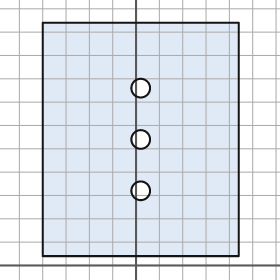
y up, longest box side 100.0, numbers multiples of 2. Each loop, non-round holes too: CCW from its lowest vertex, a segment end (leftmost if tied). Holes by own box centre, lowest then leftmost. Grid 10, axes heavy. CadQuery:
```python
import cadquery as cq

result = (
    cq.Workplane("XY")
    .moveTo(-40.0, 4.0)
    .lineTo(44.0, 4.0)
    .lineTo(44.0, 104.0)
    .lineTo(-40.0, 104.0)
    .close()
    .moveTo(2.0, 32.0)
    .circle(4.0)
    .moveTo(2.0, 54.0)
    .circle(4.0)
    .moveTo(2.0, 76.0)
    .circle(4.0)
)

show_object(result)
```